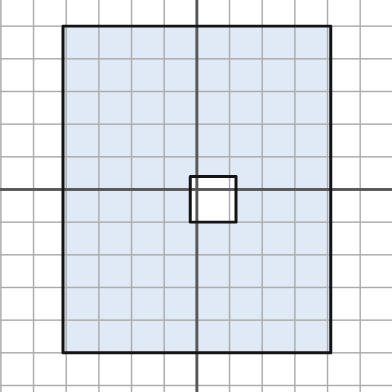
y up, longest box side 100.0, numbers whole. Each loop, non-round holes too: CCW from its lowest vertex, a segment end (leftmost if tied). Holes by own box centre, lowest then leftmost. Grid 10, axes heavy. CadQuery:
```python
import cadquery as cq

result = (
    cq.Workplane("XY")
    .moveTo(-41.0, -50.0)
    .lineTo(41.0, -50.0)
    .lineTo(41.0, 50.0)
    .lineTo(-41.0, 50.0)
    .close()
    .moveTo(-2.0, -10.0)
    .lineTo(12.0, -10.0)
    .lineTo(12.0, 4.0)
    .lineTo(-2.0, 4.0)
    .close()
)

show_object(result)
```